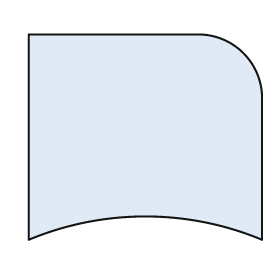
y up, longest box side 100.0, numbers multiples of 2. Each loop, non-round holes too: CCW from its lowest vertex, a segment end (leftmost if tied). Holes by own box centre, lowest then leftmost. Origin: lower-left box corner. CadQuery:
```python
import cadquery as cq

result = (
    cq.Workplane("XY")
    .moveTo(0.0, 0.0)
    .threePointArc((50.0, 10.0), (100.0, 0.0))
    .lineTo(100.0, 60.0)
    .threePointArc((92.0, 80.0), (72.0, 88.0))
    .lineTo(0.0, 88.0)
    .close()
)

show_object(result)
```